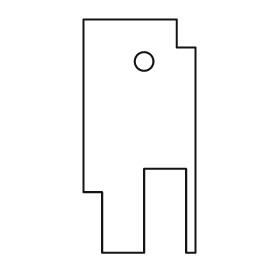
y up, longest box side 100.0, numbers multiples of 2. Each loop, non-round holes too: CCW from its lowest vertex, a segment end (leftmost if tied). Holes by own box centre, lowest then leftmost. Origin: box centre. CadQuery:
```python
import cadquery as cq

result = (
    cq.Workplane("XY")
    .moveTo(-16.0, -50.0)
    .lineTo(2.0, -50.0)
    .lineTo(2.0, -14.0)
    .lineTo(20.0, -14.0)
    .lineTo(20.0, -50.0)
    .lineTo(24.0, -50.0)
    .lineTo(24.0, 38.0)
    .lineTo(16.0, 38.0)
    .lineTo(16.0, 50.0)
    .lineTo(-24.0, 50.0)
    .lineTo(-24.0, -24.0)
    .lineTo(-16.0, -24.0)
    .close()
    .moveTo(2.0, 32.0)
    .circle(4.0)
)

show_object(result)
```